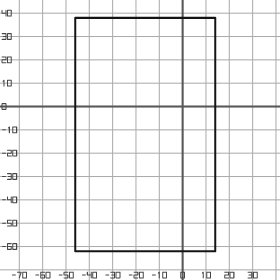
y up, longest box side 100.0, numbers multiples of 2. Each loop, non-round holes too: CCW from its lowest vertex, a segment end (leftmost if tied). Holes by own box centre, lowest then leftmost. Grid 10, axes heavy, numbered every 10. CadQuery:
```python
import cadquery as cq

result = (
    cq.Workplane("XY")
    .moveTo(-46.0, -62.0)
    .lineTo(14.0, -62.0)
    .lineTo(14.0, 38.0)
    .lineTo(-46.0, 38.0)
    .close()
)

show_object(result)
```